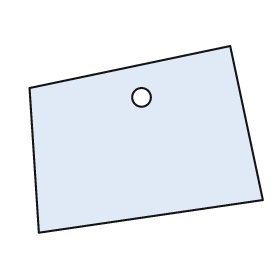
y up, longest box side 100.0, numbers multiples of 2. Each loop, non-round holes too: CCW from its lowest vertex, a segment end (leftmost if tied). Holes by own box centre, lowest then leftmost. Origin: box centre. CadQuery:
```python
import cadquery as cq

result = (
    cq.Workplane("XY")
    .moveTo(-46.0, -40.0)
    .lineTo(50.0, -26.0)
    .lineTo(36.0, 40.0)
    .lineTo(-50.0, 22.0)
    .close()
    .moveTo(-2.0, 18.0)
    .circle(4.0)
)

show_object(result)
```